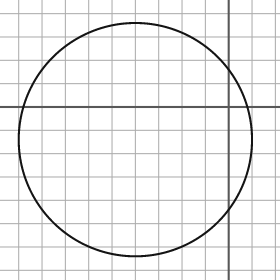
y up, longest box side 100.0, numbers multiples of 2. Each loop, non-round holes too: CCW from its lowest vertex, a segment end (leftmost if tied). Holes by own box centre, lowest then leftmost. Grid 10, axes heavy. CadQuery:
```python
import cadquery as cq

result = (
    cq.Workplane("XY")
    .moveTo(-40.0, -14.0)
    .circle(50.0)
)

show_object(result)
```